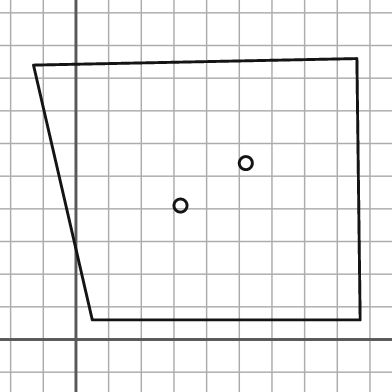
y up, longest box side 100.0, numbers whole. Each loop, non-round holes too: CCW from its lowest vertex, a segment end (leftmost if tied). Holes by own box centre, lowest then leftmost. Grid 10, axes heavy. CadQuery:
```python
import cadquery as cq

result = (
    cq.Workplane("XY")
    .moveTo(5.0, 6.0)
    .lineTo(87.0, 6.0)
    .lineTo(86.0, 86.0)
    .lineTo(-13.0, 84.0)
    .close()
    .moveTo(32.0, 41.0)
    .circle(2.0)
    .moveTo(52.0, 54.0)
    .circle(2.0)
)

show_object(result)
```